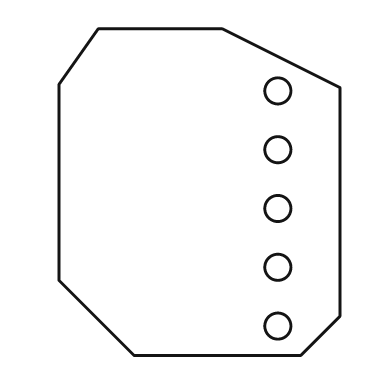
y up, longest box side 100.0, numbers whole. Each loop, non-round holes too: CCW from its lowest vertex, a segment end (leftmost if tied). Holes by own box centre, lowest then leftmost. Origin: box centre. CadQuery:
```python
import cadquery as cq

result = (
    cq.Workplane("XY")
    .moveTo(-20.0, -50.0)
    .lineTo(31.0, -50.0)
    .lineTo(43.0, -38.0)
    .lineTo(43.0, 32.0)
    .lineTo(7.0, 50.0)
    .lineTo(-31.0, 50.0)
    .lineTo(-43.0, 33.0)
    .lineTo(-43.0, -27.0)
    .close()
    .moveTo(24.0, -41.0)
    .circle(4.0)
    .moveTo(24.0, -23.0)
    .circle(4.0)
    .moveTo(24.0, -5.0)
    .circle(4.0)
    .moveTo(24.0, 13.0)
    .circle(4.0)
    .moveTo(24.0, 31.0)
    .circle(4.0)
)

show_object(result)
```